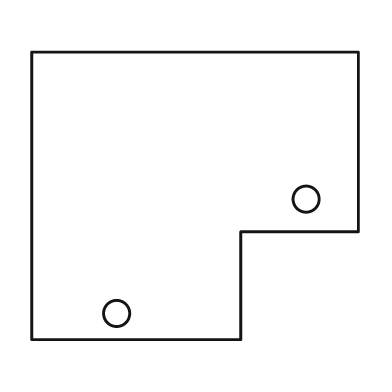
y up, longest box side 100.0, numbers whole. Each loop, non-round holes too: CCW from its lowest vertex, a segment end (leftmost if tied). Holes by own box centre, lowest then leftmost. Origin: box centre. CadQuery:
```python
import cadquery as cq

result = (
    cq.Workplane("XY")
    .moveTo(-50.0, -44.0)
    .lineTo(14.0, -44.0)
    .lineTo(14.0, -11.0)
    .lineTo(50.0, -11.0)
    .lineTo(50.0, 44.0)
    .lineTo(-50.0, 44.0)
    .close()
    .moveTo(-24.0, -36.0)
    .circle(4.0)
    .moveTo(34.0, -1.0)
    .circle(4.0)
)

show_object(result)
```